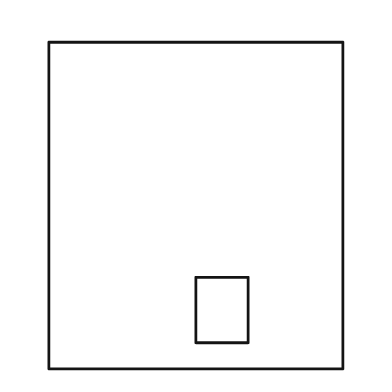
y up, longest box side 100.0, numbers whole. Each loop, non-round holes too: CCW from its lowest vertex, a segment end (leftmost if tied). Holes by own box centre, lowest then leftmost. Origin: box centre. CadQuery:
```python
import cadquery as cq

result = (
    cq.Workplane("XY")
    .moveTo(-45.0, -50.0)
    .lineTo(45.0, -50.0)
    .lineTo(45.0, 50.0)
    .lineTo(-45.0, 50.0)
    .close()
    .moveTo(0.0, -42.0)
    .lineTo(16.0, -42.0)
    .lineTo(16.0, -22.0)
    .lineTo(0.0, -22.0)
    .close()
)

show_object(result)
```